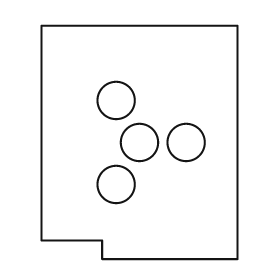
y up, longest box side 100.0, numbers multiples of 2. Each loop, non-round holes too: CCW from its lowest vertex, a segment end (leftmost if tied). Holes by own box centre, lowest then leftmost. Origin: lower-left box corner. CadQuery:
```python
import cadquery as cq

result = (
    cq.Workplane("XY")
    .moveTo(26.0, 0.0)
    .lineTo(84.0, 0.0)
    .lineTo(84.0, 100.0)
    .lineTo(0.0, 100.0)
    .lineTo(0.0, 8.0)
    .lineTo(26.0, 8.0)
    .close()
    .moveTo(32.0, 32.0)
    .circle(8.0)
    .moveTo(42.0, 50.0)
    .circle(8.0)
    .moveTo(62.0, 50.0)
    .circle(8.0)
    .moveTo(32.0, 68.0)
    .circle(8.0)
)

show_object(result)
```